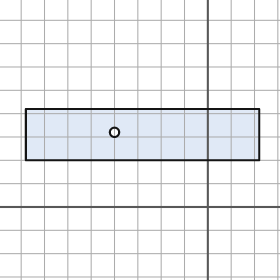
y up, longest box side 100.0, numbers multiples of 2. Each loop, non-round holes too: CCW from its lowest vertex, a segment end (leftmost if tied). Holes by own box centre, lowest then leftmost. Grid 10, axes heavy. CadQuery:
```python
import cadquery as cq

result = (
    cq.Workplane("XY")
    .moveTo(-78.0, 20.0)
    .lineTo(22.0, 20.0)
    .lineTo(22.0, 42.0)
    .lineTo(-78.0, 42.0)
    .close()
    .moveTo(-40.0, 32.0)
    .circle(2.0)
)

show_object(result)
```